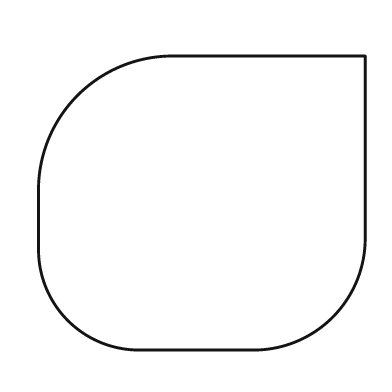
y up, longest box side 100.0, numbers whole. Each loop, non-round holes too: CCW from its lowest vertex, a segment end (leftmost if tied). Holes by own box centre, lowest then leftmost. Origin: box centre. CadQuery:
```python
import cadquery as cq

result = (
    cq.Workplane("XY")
    .moveTo(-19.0, -45.0)
    .lineTo(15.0, -45.0)
    .threePointArc((40.0, -35.0), (50.0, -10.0))
    .lineTo(50.0, 45.0)
    .lineTo(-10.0, 45.0)
    .threePointArc((-38.0, 33.0), (-50.0, 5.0))
    .lineTo(-50.0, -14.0)
    .threePointArc((-41.0, -36.0), (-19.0, -45.0))
    .close()
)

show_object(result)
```